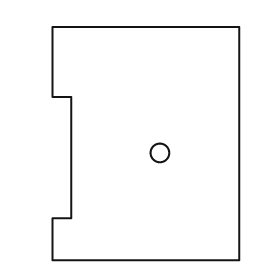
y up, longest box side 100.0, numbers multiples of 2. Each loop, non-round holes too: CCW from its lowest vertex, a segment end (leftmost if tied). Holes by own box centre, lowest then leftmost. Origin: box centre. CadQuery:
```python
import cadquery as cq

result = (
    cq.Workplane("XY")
    .moveTo(-40.0, -50.0)
    .lineTo(40.0, -50.0)
    .lineTo(40.0, 50.0)
    .lineTo(-40.0, 50.0)
    .lineTo(-40.0, 20.0)
    .lineTo(-32.0, 20.0)
    .lineTo(-32.0, -32.0)
    .lineTo(-40.0, -32.0)
    .close()
    .moveTo(6.0, -4.0)
    .circle(4.0)
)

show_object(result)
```